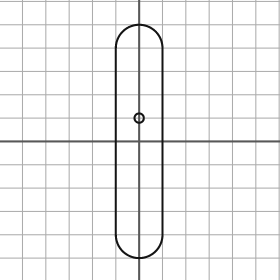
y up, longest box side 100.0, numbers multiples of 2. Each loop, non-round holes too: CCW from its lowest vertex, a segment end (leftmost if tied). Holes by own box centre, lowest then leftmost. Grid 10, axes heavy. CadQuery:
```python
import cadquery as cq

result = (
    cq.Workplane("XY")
    .moveTo(-10.0, -40.0)
    .threePointArc((0.0, -50.0), (10.0, -40.0))
    .lineTo(10.0, 40.0)
    .threePointArc((0.0, 50.0), (-10.0, 40.0))
    .close()
    .moveTo(0.0, 10.0)
    .circle(2.0)
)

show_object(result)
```